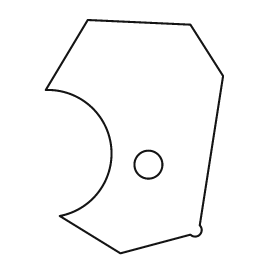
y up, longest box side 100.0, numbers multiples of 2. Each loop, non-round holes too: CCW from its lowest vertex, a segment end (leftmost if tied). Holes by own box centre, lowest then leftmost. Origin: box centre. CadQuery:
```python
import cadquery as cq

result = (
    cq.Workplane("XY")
    .moveTo(-6.0, -50.0)
    .lineTo(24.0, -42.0)
    .threePointArc((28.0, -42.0), (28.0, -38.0))
    .lineTo(38.0, 26.0)
    .lineTo(24.0, 48.0)
    .lineTo(-20.0, 50.0)
    .lineTo(-38.0, 20.0)
    .threePointArc((-10.0, -4.0), (-32.0, -34.0))
    .close()
    .moveTo(6.0, -12.0)
    .circle(6.0)
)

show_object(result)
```